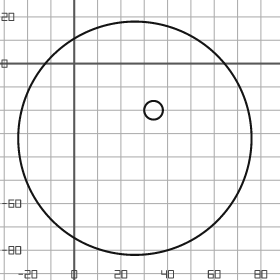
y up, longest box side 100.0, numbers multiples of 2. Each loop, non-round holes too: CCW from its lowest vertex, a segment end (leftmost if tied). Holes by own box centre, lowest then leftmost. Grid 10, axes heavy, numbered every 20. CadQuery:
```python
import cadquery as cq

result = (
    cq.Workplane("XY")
    .moveTo(26.0, -32.0)
    .circle(50.0)
    .moveTo(34.0, -20.0)
    .circle(4.0)
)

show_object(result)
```